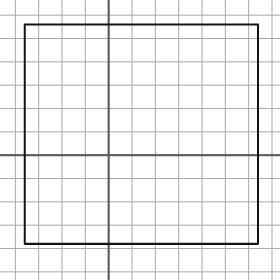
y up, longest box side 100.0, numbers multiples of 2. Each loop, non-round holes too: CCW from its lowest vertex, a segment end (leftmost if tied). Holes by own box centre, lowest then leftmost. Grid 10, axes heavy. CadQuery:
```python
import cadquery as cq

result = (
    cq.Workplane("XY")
    .moveTo(-36.0, -38.0)
    .lineTo(64.0, -38.0)
    .lineTo(64.0, 56.0)
    .lineTo(-36.0, 56.0)
    .close()
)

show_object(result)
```